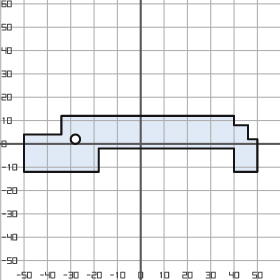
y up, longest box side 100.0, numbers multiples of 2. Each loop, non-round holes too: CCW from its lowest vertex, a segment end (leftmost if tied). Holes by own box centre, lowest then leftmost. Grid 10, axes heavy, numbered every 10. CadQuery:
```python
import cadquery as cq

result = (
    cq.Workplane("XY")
    .moveTo(-50.0, -12.0)
    .lineTo(-18.0, -12.0)
    .lineTo(-18.0, -2.0)
    .lineTo(40.0, -2.0)
    .lineTo(40.0, -12.0)
    .lineTo(50.0, -12.0)
    .lineTo(50.0, 2.0)
    .lineTo(46.0, 2.0)
    .lineTo(46.0, 8.0)
    .lineTo(40.0, 8.0)
    .lineTo(40.0, 12.0)
    .lineTo(-34.0, 12.0)
    .lineTo(-34.0, 4.0)
    .lineTo(-50.0, 4.0)
    .close()
    .moveTo(-28.0, 2.0)
    .circle(2.0)
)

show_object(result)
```